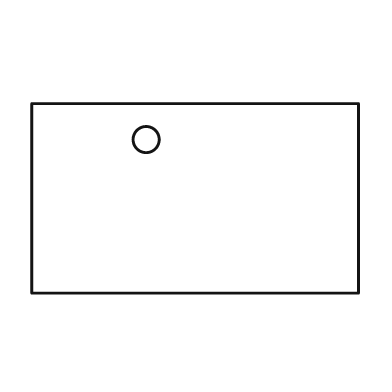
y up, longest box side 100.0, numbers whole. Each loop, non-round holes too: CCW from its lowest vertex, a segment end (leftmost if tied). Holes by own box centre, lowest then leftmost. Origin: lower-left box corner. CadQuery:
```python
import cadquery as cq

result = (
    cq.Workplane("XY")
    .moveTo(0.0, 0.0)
    .lineTo(100.0, 0.0)
    .lineTo(100.0, 58.0)
    .lineTo(0.0, 58.0)
    .close()
    .moveTo(35.0, 47.0)
    .circle(4.0)
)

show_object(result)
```